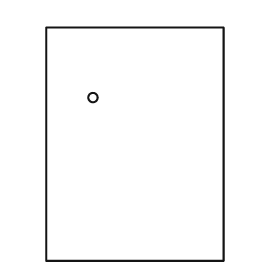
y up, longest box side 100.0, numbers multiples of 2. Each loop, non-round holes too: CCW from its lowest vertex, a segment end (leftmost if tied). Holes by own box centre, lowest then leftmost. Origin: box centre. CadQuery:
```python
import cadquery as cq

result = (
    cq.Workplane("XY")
    .moveTo(-38.0, -50.0)
    .lineTo(38.0, -50.0)
    .lineTo(38.0, 50.0)
    .lineTo(-38.0, 50.0)
    .close()
    .moveTo(-18.0, 20.0)
    .circle(2.0)
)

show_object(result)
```